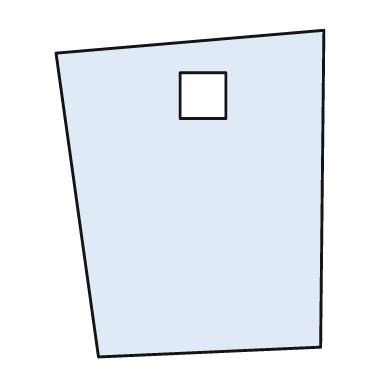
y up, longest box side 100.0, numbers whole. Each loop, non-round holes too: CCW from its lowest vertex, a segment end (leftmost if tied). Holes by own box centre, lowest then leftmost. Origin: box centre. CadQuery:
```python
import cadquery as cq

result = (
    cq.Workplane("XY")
    .moveTo(-28.0, -50.0)
    .lineTo(40.0, -47.0)
    .lineTo(41.0, 50.0)
    .lineTo(-41.0, 43.0)
    .close()
    .moveTo(-3.0, 23.0)
    .lineTo(11.0, 23.0)
    .lineTo(11.0, 37.0)
    .lineTo(-3.0, 37.0)
    .close()
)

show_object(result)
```